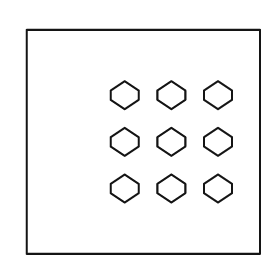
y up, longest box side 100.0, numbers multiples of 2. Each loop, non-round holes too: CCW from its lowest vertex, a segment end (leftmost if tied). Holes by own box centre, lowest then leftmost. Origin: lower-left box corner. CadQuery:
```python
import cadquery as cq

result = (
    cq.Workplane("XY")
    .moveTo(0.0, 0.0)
    .lineTo(100.0, 0.0)
    .lineTo(100.0, 96.0)
    .lineTo(0.0, 96.0)
    .close()
    .moveTo(42.0, 22.0)
    .lineTo(48.0, 26.0)
    .lineTo(48.0, 30.0)
    .lineTo(42.0, 34.0)
    .lineTo(36.0, 30.0)
    .lineTo(36.0, 26.0)
    .close()
    .moveTo(62.0, 22.0)
    .lineTo(68.0, 26.0)
    .lineTo(68.0, 30.0)
    .lineTo(62.0, 34.0)
    .lineTo(56.0, 30.0)
    .lineTo(56.0, 26.0)
    .close()
    .moveTo(82.0, 22.0)
    .lineTo(88.0, 26.0)
    .lineTo(88.0, 30.0)
    .lineTo(82.0, 34.0)
    .lineTo(76.0, 30.0)
    .lineTo(76.0, 26.0)
    .close()
    .moveTo(42.0, 42.0)
    .lineTo(48.0, 46.0)
    .lineTo(48.0, 50.0)
    .lineTo(42.0, 54.0)
    .lineTo(36.0, 50.0)
    .lineTo(36.0, 46.0)
    .close()
    .moveTo(62.0, 42.0)
    .lineTo(68.0, 46.0)
    .lineTo(68.0, 50.0)
    .lineTo(62.0, 54.0)
    .lineTo(56.0, 50.0)
    .lineTo(56.0, 46.0)
    .close()
    .moveTo(82.0, 42.0)
    .lineTo(88.0, 46.0)
    .lineTo(88.0, 50.0)
    .lineTo(82.0, 54.0)
    .lineTo(76.0, 50.0)
    .lineTo(76.0, 46.0)
    .close()
    .moveTo(42.0, 62.0)
    .lineTo(48.0, 66.0)
    .lineTo(48.0, 70.0)
    .lineTo(42.0, 74.0)
    .lineTo(36.0, 70.0)
    .lineTo(36.0, 66.0)
    .close()
    .moveTo(62.0, 62.0)
    .lineTo(68.0, 66.0)
    .lineTo(68.0, 70.0)
    .lineTo(62.0, 74.0)
    .lineTo(56.0, 70.0)
    .lineTo(56.0, 66.0)
    .close()
    .moveTo(82.0, 62.0)
    .lineTo(88.0, 66.0)
    .lineTo(88.0, 70.0)
    .lineTo(82.0, 74.0)
    .lineTo(76.0, 70.0)
    .lineTo(76.0, 66.0)
    .close()
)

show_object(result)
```